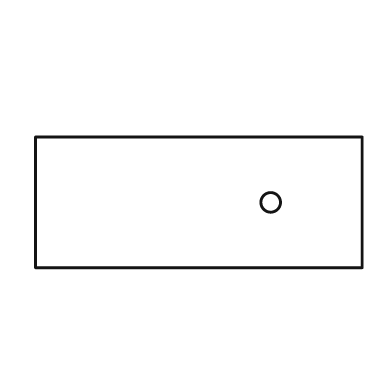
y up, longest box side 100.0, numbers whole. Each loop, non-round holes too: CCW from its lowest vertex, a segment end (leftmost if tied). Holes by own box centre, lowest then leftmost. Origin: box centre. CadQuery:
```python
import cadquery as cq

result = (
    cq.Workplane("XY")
    .moveTo(-50.0, -20.0)
    .lineTo(50.0, -20.0)
    .lineTo(50.0, 20.0)
    .lineTo(-50.0, 20.0)
    .close()
    .moveTo(22.0, 0.0)
    .circle(3.0)
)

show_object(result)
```